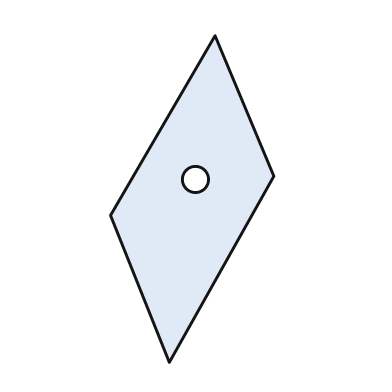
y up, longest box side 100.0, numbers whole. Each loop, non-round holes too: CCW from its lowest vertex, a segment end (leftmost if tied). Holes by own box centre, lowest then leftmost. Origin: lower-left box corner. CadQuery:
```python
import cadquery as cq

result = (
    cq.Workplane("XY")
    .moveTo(18.0, 0.0)
    .lineTo(50.0, 57.0)
    .lineTo(32.0, 100.0)
    .lineTo(0.0, 45.0)
    .close()
    .moveTo(26.0, 56.0)
    .circle(4.0)
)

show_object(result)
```